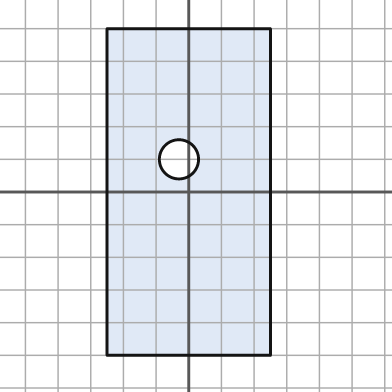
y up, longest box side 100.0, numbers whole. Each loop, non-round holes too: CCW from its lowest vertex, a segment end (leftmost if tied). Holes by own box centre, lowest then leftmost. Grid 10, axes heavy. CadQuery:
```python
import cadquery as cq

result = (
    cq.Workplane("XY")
    .moveTo(-25.0, -50.0)
    .lineTo(25.0, -50.0)
    .lineTo(25.0, 50.0)
    .lineTo(-25.0, 50.0)
    .close()
    .moveTo(-3.0, 10.0)
    .circle(6.0)
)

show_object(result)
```